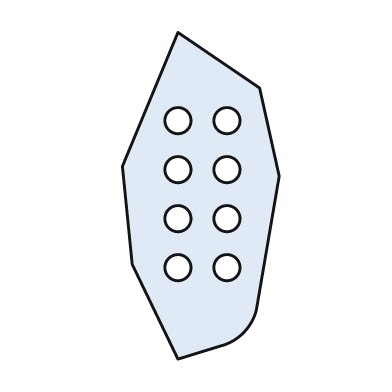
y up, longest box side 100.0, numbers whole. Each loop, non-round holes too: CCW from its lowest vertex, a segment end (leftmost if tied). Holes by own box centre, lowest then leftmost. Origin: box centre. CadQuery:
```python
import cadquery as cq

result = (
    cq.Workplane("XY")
    .moveTo(-7.0, -50.0)
    .lineTo(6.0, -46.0)
    .threePointArc((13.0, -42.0), (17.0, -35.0))
    .lineTo(24.0, 6.0)
    .lineTo(18.0, 33.0)
    .lineTo(-7.0, 50.0)
    .lineTo(-24.0, 9.0)
    .lineTo(-21.0, -21.0)
    .close()
    .moveTo(-7.0, -22.0)
    .circle(4.0)
    .moveTo(8.0, -22.0)
    .circle(4.0)
    .moveTo(-7.0, -7.0)
    .circle(4.0)
    .moveTo(8.0, -7.0)
    .circle(4.0)
    .moveTo(-7.0, 8.0)
    .circle(4.0)
    .moveTo(8.0, 8.0)
    .circle(4.0)
    .moveTo(-7.0, 23.0)
    .circle(4.0)
    .moveTo(8.0, 23.0)
    .circle(4.0)
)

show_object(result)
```